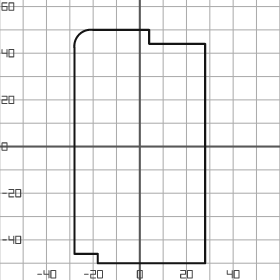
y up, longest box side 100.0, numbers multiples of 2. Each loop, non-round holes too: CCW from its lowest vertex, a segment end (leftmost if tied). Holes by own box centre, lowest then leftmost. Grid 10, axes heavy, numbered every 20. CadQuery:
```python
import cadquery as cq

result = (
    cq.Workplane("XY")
    .moveTo(-18.0, -50.0)
    .lineTo(28.0, -50.0)
    .lineTo(28.0, 44.0)
    .lineTo(4.0, 44.0)
    .lineTo(4.0, 50.0)
    .lineTo(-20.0, 50.0)
    .threePointArc((-26.0, 48.0), (-28.0, 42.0))
    .lineTo(-28.0, -46.0)
    .lineTo(-18.0, -46.0)
    .close()
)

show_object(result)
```